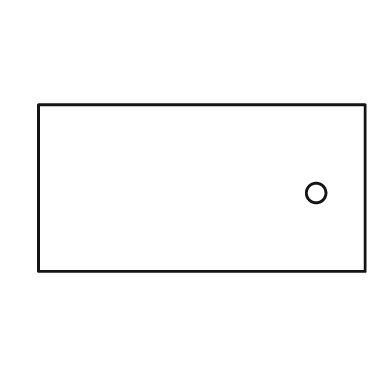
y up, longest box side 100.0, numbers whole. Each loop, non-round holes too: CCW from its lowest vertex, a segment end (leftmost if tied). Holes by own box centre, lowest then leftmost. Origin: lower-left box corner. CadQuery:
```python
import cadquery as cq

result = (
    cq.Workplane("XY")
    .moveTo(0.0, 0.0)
    .lineTo(100.0, 0.0)
    .lineTo(100.0, 51.0)
    .lineTo(0.0, 51.0)
    .close()
    .moveTo(85.0, 24.0)
    .circle(3.0)
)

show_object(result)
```